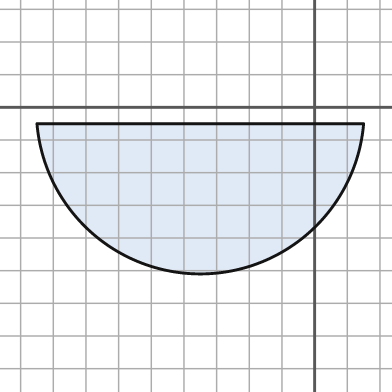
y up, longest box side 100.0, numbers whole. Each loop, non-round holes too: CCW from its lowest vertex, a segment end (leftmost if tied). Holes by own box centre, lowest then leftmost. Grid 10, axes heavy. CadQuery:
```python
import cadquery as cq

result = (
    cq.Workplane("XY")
    .moveTo(-85.0, -5.0)
    .threePointArc((-35.0, -51.0), (15.0, -5.0))
    .close()
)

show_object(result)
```